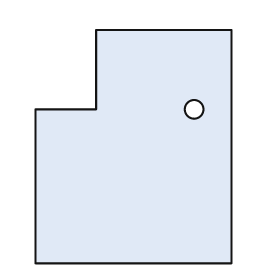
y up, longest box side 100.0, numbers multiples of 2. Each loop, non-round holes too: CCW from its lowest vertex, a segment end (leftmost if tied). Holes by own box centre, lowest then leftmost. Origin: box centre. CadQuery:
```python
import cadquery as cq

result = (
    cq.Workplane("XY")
    .moveTo(-42.0, -50.0)
    .lineTo(42.0, -50.0)
    .lineTo(42.0, 50.0)
    .lineTo(-16.0, 50.0)
    .lineTo(-16.0, 16.0)
    .lineTo(-42.0, 16.0)
    .close()
    .moveTo(26.0, 16.0)
    .circle(4.0)
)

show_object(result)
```